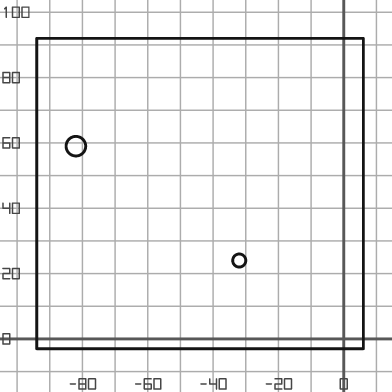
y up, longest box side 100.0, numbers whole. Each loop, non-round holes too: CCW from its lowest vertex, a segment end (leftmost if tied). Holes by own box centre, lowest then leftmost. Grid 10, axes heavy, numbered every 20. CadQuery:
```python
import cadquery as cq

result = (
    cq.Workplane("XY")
    .moveTo(-94.0, -3.0)
    .lineTo(6.0, -3.0)
    .lineTo(6.0, 92.0)
    .lineTo(-94.0, 92.0)
    .close()
    .moveTo(-32.0, 24.0)
    .circle(2.0)
    .moveTo(-82.0, 59.0)
    .circle(3.0)
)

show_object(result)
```